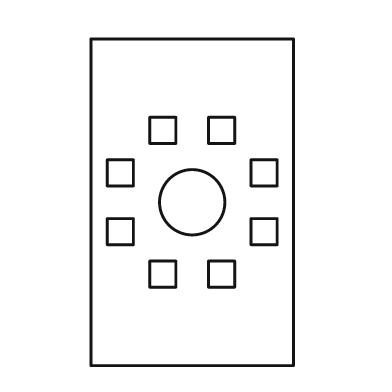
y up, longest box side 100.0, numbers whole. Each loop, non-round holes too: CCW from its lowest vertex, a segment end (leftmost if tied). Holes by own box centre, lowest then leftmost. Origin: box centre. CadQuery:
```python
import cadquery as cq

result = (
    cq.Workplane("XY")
    .moveTo(-31.0, -50.0)
    .lineTo(31.0, -50.0)
    .lineTo(31.0, 50.0)
    .lineTo(-31.0, 50.0)
    .close()
    .moveTo(-13.0, -26.0)
    .lineTo(-5.0, -26.0)
    .lineTo(-5.0, -18.0)
    .lineTo(-13.0, -18.0)
    .close()
    .moveTo(5.0, -26.0)
    .lineTo(13.0, -26.0)
    .lineTo(13.0, -18.0)
    .lineTo(5.0, -18.0)
    .close()
    .moveTo(-26.0, -13.0)
    .lineTo(-18.0, -13.0)
    .lineTo(-18.0, -5.0)
    .lineTo(-26.0, -5.0)
    .close()
    .moveTo(18.0, -13.0)
    .lineTo(26.0, -13.0)
    .lineTo(26.0, -5.0)
    .lineTo(18.0, -5.0)
    .close()
    .moveTo(0.0, 0.0)
    .circle(10.0)
    .moveTo(-26.0, 5.0)
    .lineTo(-18.0, 5.0)
    .lineTo(-18.0, 13.0)
    .lineTo(-26.0, 13.0)
    .close()
    .moveTo(18.0, 5.0)
    .lineTo(26.0, 5.0)
    .lineTo(26.0, 13.0)
    .lineTo(18.0, 13.0)
    .close()
    .moveTo(-13.0, 18.0)
    .lineTo(-5.0, 18.0)
    .lineTo(-5.0, 26.0)
    .lineTo(-13.0, 26.0)
    .close()
    .moveTo(5.0, 18.0)
    .lineTo(13.0, 18.0)
    .lineTo(13.0, 26.0)
    .lineTo(5.0, 26.0)
    .close()
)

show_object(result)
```